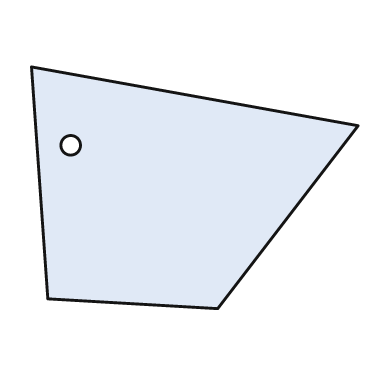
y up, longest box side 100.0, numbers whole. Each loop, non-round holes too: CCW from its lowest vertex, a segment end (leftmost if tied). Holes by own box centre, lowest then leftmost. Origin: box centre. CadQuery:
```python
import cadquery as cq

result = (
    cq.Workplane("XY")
    .moveTo(7.0, -37.0)
    .lineTo(50.0, 19.0)
    .lineTo(-50.0, 37.0)
    .lineTo(-45.0, -34.0)
    .close()
    .moveTo(-38.0, 13.0)
    .circle(3.0)
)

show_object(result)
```